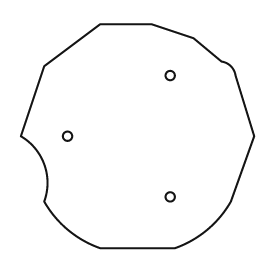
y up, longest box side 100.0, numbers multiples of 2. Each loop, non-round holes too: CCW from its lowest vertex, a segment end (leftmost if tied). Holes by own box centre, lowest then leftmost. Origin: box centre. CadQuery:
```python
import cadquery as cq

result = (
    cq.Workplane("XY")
    .moveTo(-16.0, -48.0)
    .lineTo(16.0, -48.0)
    .threePointArc((30.0, -40.0), (40.0, -28.0))
    .lineTo(50.0, 0.0)
    .lineTo(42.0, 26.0)
    .threePointArc((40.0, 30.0), (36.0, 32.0))
    .lineTo(24.0, 42.0)
    .lineTo(6.0, 48.0)
    .lineTo(-16.0, 48.0)
    .lineTo(-40.0, 30.0)
    .lineTo(-50.0, 0.0)
    .threePointArc((-40.0, -12.0), (-40.0, -28.0))
    .threePointArc((-30.0, -40.0), (-16.0, -48.0))
    .close()
    .moveTo(14.0, -26.0)
    .circle(2.0)
    .moveTo(-30.0, 0.0)
    .circle(2.0)
    .moveTo(14.0, 26.0)
    .circle(2.0)
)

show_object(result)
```